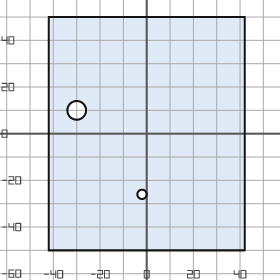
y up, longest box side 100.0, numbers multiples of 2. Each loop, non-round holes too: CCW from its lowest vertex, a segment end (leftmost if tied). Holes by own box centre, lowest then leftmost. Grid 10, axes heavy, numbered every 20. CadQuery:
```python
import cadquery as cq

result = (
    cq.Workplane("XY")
    .moveTo(-42.0, -50.0)
    .lineTo(42.0, -50.0)
    .lineTo(42.0, 50.0)
    .lineTo(-42.0, 50.0)
    .close()
    .moveTo(-2.0, -26.0)
    .circle(2.0)
    .moveTo(-30.0, 10.0)
    .circle(4.0)
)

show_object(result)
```